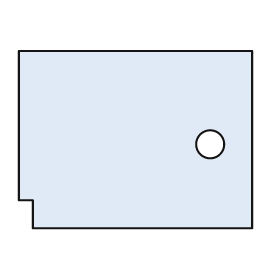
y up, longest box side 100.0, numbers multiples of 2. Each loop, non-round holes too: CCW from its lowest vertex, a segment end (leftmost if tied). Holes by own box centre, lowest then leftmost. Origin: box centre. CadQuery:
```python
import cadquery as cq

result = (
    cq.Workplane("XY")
    .moveTo(-44.0, -38.0)
    .lineTo(50.0, -38.0)
    .lineTo(50.0, 38.0)
    .lineTo(-50.0, 38.0)
    .lineTo(-50.0, -26.0)
    .lineTo(-44.0, -26.0)
    .close()
    .moveTo(32.0, -2.0)
    .circle(6.0)
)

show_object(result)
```